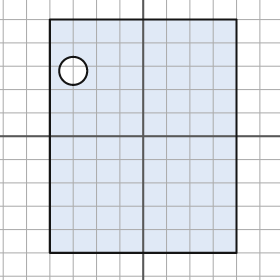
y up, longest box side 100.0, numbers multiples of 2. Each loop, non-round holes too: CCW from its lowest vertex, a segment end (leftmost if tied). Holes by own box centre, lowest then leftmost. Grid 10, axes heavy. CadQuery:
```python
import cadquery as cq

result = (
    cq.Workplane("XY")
    .moveTo(-40.0, -50.0)
    .lineTo(40.0, -50.0)
    .lineTo(40.0, 50.0)
    .lineTo(-40.0, 50.0)
    .close()
    .moveTo(-30.0, 28.0)
    .circle(6.0)
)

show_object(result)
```